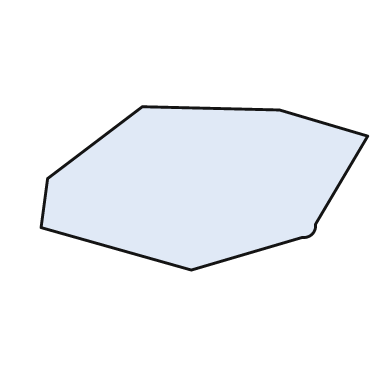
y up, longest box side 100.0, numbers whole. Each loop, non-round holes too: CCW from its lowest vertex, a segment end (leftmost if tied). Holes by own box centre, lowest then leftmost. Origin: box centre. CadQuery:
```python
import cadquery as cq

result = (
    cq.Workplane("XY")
    .moveTo(-4.0, -25.0)
    .lineTo(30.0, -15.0)
    .threePointArc((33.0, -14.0), (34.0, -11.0))
    .lineTo(50.0, 16.0)
    .lineTo(23.0, 24.0)
    .lineTo(-19.0, 25.0)
    .lineTo(-48.0, 3.0)
    .lineTo(-50.0, -12.0)
    .close()
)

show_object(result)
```